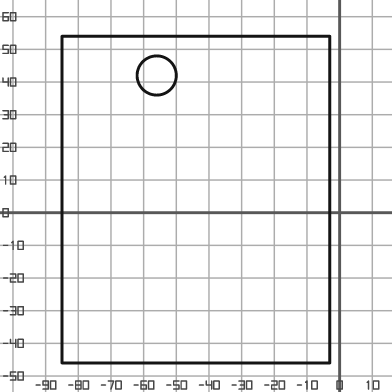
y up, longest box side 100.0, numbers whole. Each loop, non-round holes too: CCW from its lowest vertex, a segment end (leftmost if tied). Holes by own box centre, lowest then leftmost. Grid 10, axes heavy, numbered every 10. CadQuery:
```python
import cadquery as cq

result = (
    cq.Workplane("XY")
    .moveTo(-85.0, -46.0)
    .lineTo(-3.0, -46.0)
    .lineTo(-3.0, 54.0)
    .lineTo(-85.0, 54.0)
    .close()
    .moveTo(-56.0, 42.0)
    .circle(6.0)
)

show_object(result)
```